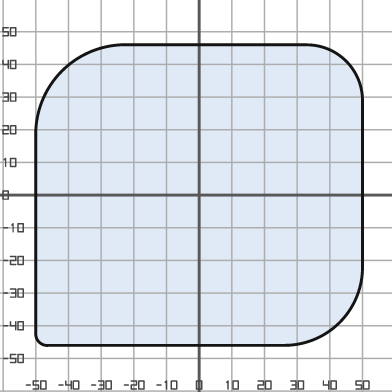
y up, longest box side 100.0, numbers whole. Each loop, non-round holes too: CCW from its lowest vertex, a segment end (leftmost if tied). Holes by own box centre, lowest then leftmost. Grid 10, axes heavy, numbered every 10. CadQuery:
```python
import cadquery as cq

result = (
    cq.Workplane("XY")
    .moveTo(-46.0, -46.0)
    .lineTo(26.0, -46.0)
    .threePointArc((43.0, -39.0), (50.0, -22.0))
    .lineTo(50.0, 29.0)
    .threePointArc((45.0, 41.0), (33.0, 46.0))
    .lineTo(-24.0, 46.0)
    .threePointArc((-42.0, 38.0), (-50.0, 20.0))
    .lineTo(-50.0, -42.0)
    .threePointArc((-49.0, -45.0), (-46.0, -46.0))
    .close()
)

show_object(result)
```